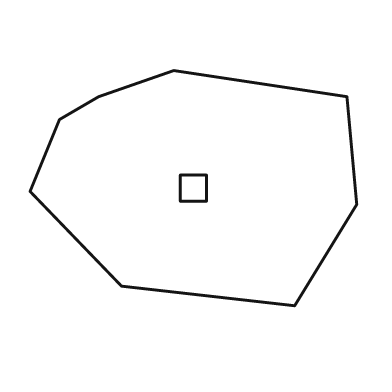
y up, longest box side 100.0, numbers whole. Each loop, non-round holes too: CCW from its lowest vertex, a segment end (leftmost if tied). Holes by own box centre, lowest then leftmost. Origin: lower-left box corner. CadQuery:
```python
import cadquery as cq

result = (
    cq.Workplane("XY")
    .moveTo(81.0, 0.0)
    .lineTo(100.0, 31.0)
    .lineTo(97.0, 64.0)
    .lineTo(44.0, 72.0)
    .lineTo(21.0, 64.0)
    .lineTo(9.0, 57.0)
    .lineTo(0.0, 35.0)
    .lineTo(28.0, 6.0)
    .close()
    .moveTo(46.0, 32.0)
    .lineTo(54.0, 32.0)
    .lineTo(54.0, 40.0)
    .lineTo(46.0, 40.0)
    .close()
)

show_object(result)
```